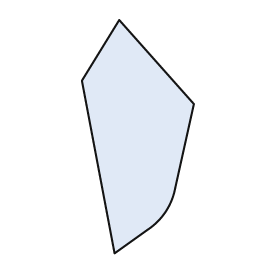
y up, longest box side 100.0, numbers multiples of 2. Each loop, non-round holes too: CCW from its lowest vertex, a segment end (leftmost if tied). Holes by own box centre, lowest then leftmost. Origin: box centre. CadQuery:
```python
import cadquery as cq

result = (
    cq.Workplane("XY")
    .moveTo(-10.0, -50.0)
    .lineTo(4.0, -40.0)
    .threePointArc((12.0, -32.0), (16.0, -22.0))
    .lineTo(24.0, 14.0)
    .lineTo(-8.0, 50.0)
    .lineTo(-24.0, 24.0)
    .close()
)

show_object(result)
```